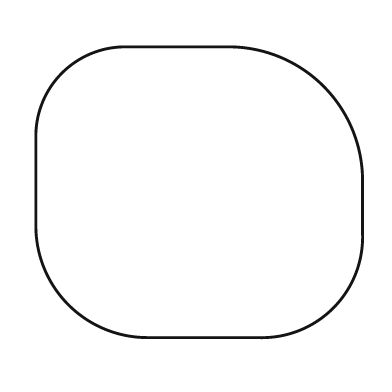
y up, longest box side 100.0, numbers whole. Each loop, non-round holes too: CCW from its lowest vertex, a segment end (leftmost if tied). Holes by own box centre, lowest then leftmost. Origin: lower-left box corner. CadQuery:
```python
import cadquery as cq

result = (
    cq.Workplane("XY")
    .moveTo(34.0, 0.0)
    .lineTo(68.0, 0.0)
    .threePointArc((91.0, 9.0), (100.0, 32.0))
    .lineTo(100.0, 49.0)
    .threePointArc((88.0, 77.0), (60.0, 89.0))
    .lineTo(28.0, 89.0)
    .threePointArc((8.0, 81.0), (0.0, 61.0))
    .lineTo(0.0, 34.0)
    .threePointArc((10.0, 10.0), (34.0, 0.0))
    .close()
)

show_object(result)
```